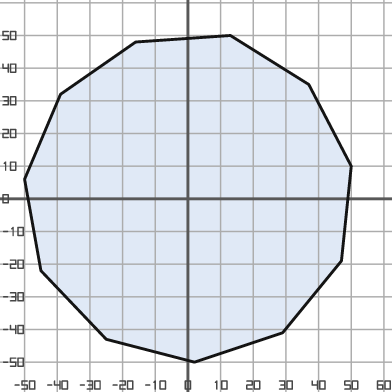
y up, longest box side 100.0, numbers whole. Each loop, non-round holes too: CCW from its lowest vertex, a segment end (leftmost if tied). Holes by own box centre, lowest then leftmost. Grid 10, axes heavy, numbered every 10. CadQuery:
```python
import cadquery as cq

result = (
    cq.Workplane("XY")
    .moveTo(2.0, -50.0)
    .lineTo(29.0, -41.0)
    .lineTo(47.0, -19.0)
    .lineTo(50.0, 10.0)
    .lineTo(37.0, 35.0)
    .lineTo(13.0, 50.0)
    .lineTo(-16.0, 48.0)
    .lineTo(-39.0, 32.0)
    .lineTo(-50.0, 6.0)
    .lineTo(-45.0, -22.0)
    .lineTo(-25.0, -43.0)
    .close()
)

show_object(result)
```